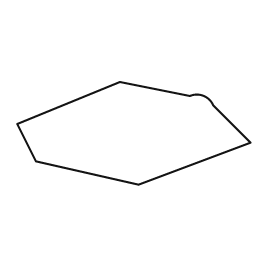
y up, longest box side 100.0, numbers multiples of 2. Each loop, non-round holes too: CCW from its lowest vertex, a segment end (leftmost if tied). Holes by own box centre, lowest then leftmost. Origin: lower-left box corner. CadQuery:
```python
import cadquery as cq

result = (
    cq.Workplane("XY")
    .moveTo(52.0, 0.0)
    .lineTo(100.0, 18.0)
    .lineTo(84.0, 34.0)
    .threePointArc((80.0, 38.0), (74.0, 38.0))
    .lineTo(44.0, 44.0)
    .lineTo(0.0, 26.0)
    .lineTo(8.0, 10.0)
    .close()
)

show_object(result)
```